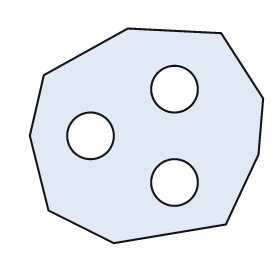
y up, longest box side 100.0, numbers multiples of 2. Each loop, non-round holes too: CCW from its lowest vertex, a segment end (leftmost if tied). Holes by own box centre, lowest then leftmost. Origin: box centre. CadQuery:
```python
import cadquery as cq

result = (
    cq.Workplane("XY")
    .moveTo(-14.0, -46.0)
    .lineTo(34.0, -38.0)
    .lineTo(48.0, -8.0)
    .lineTo(50.0, 16.0)
    .lineTo(32.0, 44.0)
    .lineTo(-8.0, 46.0)
    .lineTo(-44.0, 26.0)
    .lineTo(-50.0, 0.0)
    .lineTo(-42.0, -32.0)
    .close()
    .moveTo(12.0, -20.0)
    .circle(10.0)
    .moveTo(-24.0, 0.0)
    .circle(10.0)
    .moveTo(12.0, 20.0)
    .circle(10.0)
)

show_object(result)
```